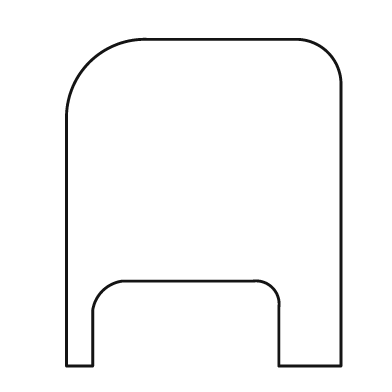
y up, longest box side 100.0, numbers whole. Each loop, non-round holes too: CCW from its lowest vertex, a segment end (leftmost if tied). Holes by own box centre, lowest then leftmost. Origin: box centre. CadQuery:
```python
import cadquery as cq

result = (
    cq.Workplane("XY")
    .moveTo(-42.0, -50.0)
    .lineTo(-34.0, -50.0)
    .lineTo(-34.0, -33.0)
    .threePointArc((-31.0, -27.0), (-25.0, -24.0))
    .lineTo(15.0, -24.0)
    .threePointArc((21.0, -26.0), (23.0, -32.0))
    .lineTo(23.0, -50.0)
    .lineTo(42.0, -50.0)
    .lineTo(42.0, 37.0)
    .threePointArc((38.0, 46.0), (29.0, 50.0))
    .lineTo(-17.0, 50.0)
    .threePointArc((-35.0, 43.0), (-42.0, 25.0))
    .close()
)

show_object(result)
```